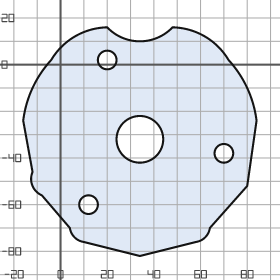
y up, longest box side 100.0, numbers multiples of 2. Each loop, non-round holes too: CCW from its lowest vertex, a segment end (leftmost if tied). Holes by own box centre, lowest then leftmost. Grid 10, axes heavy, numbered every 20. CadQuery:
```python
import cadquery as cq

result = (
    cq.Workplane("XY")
    .moveTo(34.0, -82.0)
    .lineTo(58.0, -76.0)
    .threePointArc((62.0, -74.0), (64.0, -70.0))
    .lineTo(80.0, -52.0)
    .lineTo(84.0, -24.0)
    .threePointArc((80.0, -10.0), (72.0, 2.0))
    .threePointArc((62.0, 12.0), (48.0, 16.0))
    .threePointArc((34.0, 10.0), (20.0, 16.0))
    .threePointArc((6.0, 12.0), (-4.0, 2.0))
    .threePointArc((-12.0, -10.0), (-16.0, -24.0))
    .lineTo(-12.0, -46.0)
    .threePointArc((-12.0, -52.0), (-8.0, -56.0))
    .lineTo(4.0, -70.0)
    .threePointArc((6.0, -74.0), (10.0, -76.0))
    .close()
    .moveTo(12.0, -60.0)
    .circle(4.0)
    .moveTo(70.0, -38.0)
    .circle(4.0)
    .moveTo(34.0, -32.0)
    .circle(10.0)
    .moveTo(20.0, 2.0)
    .circle(4.0)
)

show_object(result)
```